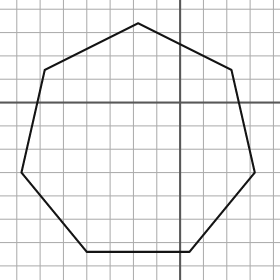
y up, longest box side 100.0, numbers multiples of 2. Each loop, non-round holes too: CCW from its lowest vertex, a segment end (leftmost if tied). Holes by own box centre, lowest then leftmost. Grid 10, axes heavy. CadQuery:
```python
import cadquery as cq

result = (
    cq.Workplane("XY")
    .moveTo(-40.0, -64.0)
    .lineTo(4.0, -64.0)
    .lineTo(32.0, -30.0)
    .lineTo(22.0, 14.0)
    .lineTo(-18.0, 34.0)
    .lineTo(-58.0, 14.0)
    .lineTo(-68.0, -30.0)
    .close()
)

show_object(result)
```